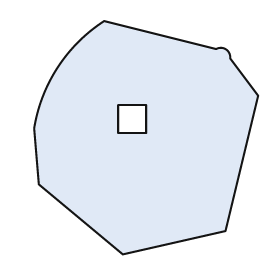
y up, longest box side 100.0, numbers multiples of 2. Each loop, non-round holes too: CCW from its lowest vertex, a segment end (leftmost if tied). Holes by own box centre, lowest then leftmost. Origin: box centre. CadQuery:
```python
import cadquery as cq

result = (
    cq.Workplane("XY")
    .moveTo(-10.0, -50.0)
    .lineTo(34.0, -40.0)
    .lineTo(48.0, 18.0)
    .lineTo(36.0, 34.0)
    .threePointArc((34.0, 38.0), (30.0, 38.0))
    .lineTo(-18.0, 50.0)
    .threePointArc((-38.0, 30.0), (-48.0, 4.0))
    .lineTo(-46.0, -20.0)
    .close()
    .moveTo(-12.0, 2.0)
    .lineTo(0.0, 2.0)
    .lineTo(0.0, 14.0)
    .lineTo(-12.0, 14.0)
    .close()
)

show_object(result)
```